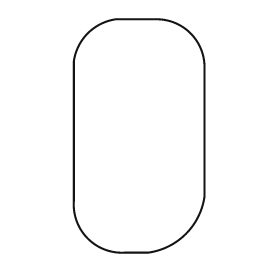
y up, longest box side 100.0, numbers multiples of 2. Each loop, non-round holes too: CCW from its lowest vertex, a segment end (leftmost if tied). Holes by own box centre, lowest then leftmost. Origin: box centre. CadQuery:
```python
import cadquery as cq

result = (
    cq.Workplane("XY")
    .moveTo(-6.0, -50.0)
    .lineTo(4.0, -50.0)
    .threePointArc((20.0, -42.0), (28.0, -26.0))
    .lineTo(28.0, 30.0)
    .threePointArc((22.0, 44.0), (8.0, 50.0))
    .lineTo(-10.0, 50.0)
    .threePointArc((-22.0, 44.0), (-28.0, 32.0))
    .lineTo(-28.0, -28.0)
    .threePointArc((-22.0, -44.0), (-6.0, -50.0))
    .close()
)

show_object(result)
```